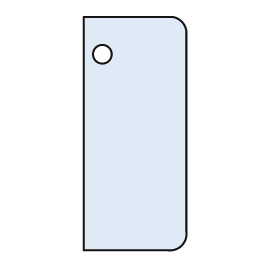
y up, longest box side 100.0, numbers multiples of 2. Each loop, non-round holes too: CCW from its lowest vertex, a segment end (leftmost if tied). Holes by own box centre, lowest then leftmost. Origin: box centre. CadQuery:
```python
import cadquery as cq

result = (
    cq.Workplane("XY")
    .moveTo(-22.0, -50.0)
    .lineTo(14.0, -50.0)
    .threePointArc((20.0, -48.0), (22.0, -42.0))
    .lineTo(22.0, 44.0)
    .threePointArc((20.0, 48.0), (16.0, 50.0))
    .lineTo(-22.0, 50.0)
    .close()
    .moveTo(-14.0, 34.0)
    .circle(4.0)
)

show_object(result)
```